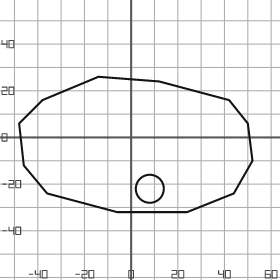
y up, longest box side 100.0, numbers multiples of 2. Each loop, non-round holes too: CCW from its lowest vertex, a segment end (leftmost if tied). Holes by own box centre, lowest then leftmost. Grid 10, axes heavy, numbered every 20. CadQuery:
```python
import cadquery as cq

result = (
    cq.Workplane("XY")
    .moveTo(-6.0, -32.0)
    .lineTo(24.0, -32.0)
    .lineTo(44.0, -24.0)
    .lineTo(52.0, -10.0)
    .lineTo(50.0, 6.0)
    .lineTo(42.0, 16.0)
    .lineTo(12.0, 24.0)
    .lineTo(-14.0, 26.0)
    .lineTo(-38.0, 16.0)
    .lineTo(-48.0, 6.0)
    .lineTo(-46.0, -12.0)
    .lineTo(-36.0, -24.0)
    .close()
    .moveTo(8.0, -22.0)
    .circle(6.0)
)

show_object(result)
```